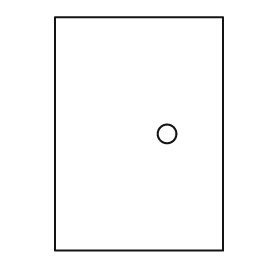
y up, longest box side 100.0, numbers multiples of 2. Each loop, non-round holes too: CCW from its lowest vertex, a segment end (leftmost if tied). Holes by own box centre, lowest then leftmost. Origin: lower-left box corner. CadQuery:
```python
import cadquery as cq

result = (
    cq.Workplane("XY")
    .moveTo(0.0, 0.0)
    .lineTo(72.0, 0.0)
    .lineTo(72.0, 100.0)
    .lineTo(0.0, 100.0)
    .close()
    .moveTo(48.0, 50.0)
    .circle(4.0)
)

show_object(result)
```